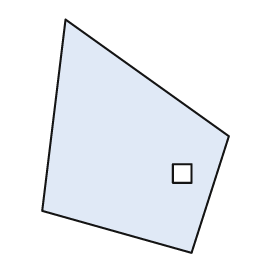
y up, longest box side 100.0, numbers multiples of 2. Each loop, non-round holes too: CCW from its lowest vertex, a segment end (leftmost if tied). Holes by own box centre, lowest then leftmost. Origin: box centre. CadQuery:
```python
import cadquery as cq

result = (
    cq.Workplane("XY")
    .moveTo(24.0, -50.0)
    .lineTo(40.0, 0.0)
    .lineTo(-30.0, 50.0)
    .lineTo(-40.0, -32.0)
    .close()
    .moveTo(16.0, -20.0)
    .lineTo(24.0, -20.0)
    .lineTo(24.0, -12.0)
    .lineTo(16.0, -12.0)
    .close()
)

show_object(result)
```